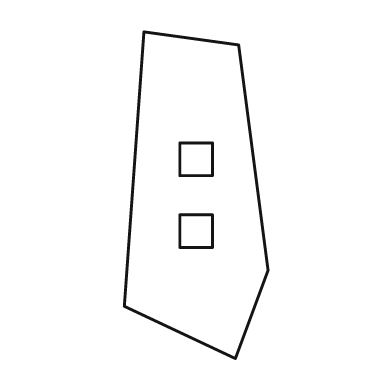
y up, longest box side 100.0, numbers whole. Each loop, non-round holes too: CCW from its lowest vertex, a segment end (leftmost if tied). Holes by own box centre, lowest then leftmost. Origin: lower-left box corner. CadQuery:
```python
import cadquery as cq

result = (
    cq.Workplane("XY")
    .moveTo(34.0, 0.0)
    .lineTo(44.0, 27.0)
    .lineTo(35.0, 96.0)
    .lineTo(6.0, 100.0)
    .lineTo(0.0, 16.0)
    .close()
    .moveTo(17.0, 34.0)
    .lineTo(27.0, 34.0)
    .lineTo(27.0, 44.0)
    .lineTo(17.0, 44.0)
    .close()
    .moveTo(17.0, 56.0)
    .lineTo(27.0, 56.0)
    .lineTo(27.0, 66.0)
    .lineTo(17.0, 66.0)
    .close()
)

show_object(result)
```